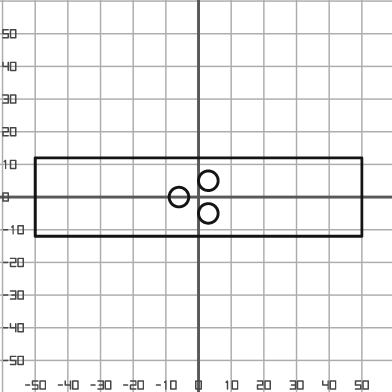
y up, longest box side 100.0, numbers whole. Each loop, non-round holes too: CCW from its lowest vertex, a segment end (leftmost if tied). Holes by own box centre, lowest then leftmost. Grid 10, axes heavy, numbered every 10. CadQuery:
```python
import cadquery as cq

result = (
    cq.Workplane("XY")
    .moveTo(-50.0, -12.0)
    .lineTo(50.0, -12.0)
    .lineTo(50.0, 12.0)
    .lineTo(-50.0, 12.0)
    .close()
    .moveTo(3.0, -5.0)
    .circle(3.0)
    .moveTo(-6.0, 0.0)
    .circle(3.0)
    .moveTo(3.0, 5.0)
    .circle(3.0)
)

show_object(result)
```